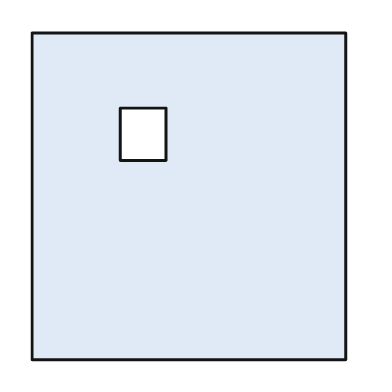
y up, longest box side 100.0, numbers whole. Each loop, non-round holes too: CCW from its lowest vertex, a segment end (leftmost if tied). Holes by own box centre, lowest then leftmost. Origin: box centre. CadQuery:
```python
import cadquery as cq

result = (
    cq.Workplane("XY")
    .moveTo(-48.0, -50.0)
    .lineTo(48.0, -50.0)
    .lineTo(48.0, 50.0)
    .lineTo(-48.0, 50.0)
    .close()
    .moveTo(-21.0, 11.0)
    .lineTo(-7.0, 11.0)
    .lineTo(-7.0, 27.0)
    .lineTo(-21.0, 27.0)
    .close()
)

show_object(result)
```